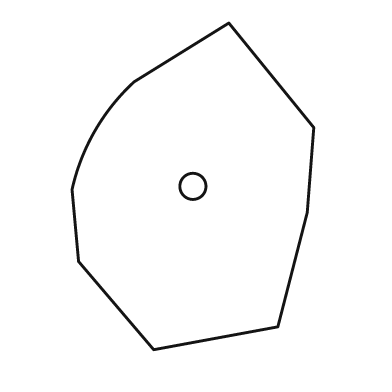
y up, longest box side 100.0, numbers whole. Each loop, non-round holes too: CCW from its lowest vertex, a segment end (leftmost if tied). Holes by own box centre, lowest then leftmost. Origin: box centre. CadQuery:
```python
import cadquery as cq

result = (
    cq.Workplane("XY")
    .moveTo(-12.0, -50.0)
    .lineTo(26.0, -43.0)
    .lineTo(35.0, -8.0)
    .lineTo(37.0, 18.0)
    .lineTo(11.0, 50.0)
    .lineTo(-18.0, 32.0)
    .threePointArc((-30.0, 17.0), (-37.0, -1.0))
    .lineTo(-35.0, -23.0)
    .close()
    .moveTo(0.0, 0.0)
    .circle(4.0)
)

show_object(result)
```